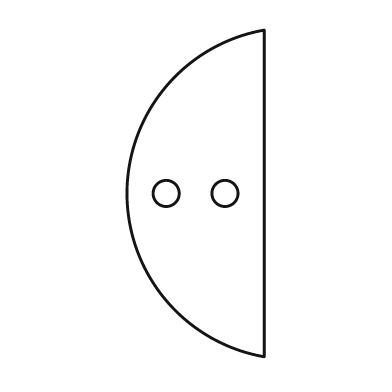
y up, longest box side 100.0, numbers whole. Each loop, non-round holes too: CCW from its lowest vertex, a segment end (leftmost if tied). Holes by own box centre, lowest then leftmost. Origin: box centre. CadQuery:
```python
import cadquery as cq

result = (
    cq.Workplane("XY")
    .moveTo(21.0, -50.0)
    .lineTo(21.0, 50.0)
    .threePointArc((-21.0, 0.0), (21.0, -50.0))
    .close()
    .moveTo(-9.0, 0.0)
    .circle(4.0)
    .moveTo(9.0, 0.0)
    .circle(4.0)
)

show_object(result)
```